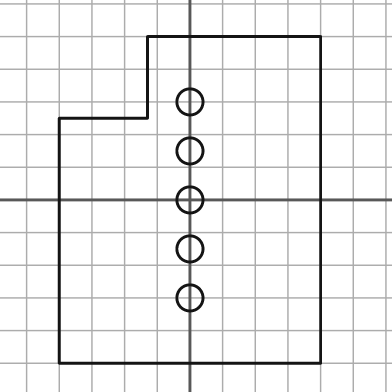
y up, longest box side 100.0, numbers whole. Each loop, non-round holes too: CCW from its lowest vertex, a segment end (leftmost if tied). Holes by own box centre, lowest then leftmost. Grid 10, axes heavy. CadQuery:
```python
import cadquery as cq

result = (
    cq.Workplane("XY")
    .moveTo(-40.0, -50.0)
    .lineTo(40.0, -50.0)
    .lineTo(40.0, 50.0)
    .lineTo(-13.0, 50.0)
    .lineTo(-13.0, 25.0)
    .lineTo(-40.0, 25.0)
    .close()
    .moveTo(0.0, -30.0)
    .circle(4.0)
    .moveTo(0.0, -15.0)
    .circle(4.0)
    .moveTo(0.0, 0.0)
    .circle(4.0)
    .moveTo(0.0, 15.0)
    .circle(4.0)
    .moveTo(0.0, 30.0)
    .circle(4.0)
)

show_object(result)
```